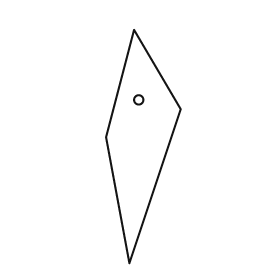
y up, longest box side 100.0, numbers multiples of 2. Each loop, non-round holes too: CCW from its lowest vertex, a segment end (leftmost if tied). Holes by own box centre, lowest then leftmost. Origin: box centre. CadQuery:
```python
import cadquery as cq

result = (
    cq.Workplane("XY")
    .moveTo(-6.0, -50.0)
    .lineTo(16.0, 16.0)
    .lineTo(-4.0, 50.0)
    .lineTo(-16.0, 4.0)
    .close()
    .moveTo(-2.0, 20.0)
    .circle(2.0)
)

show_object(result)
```